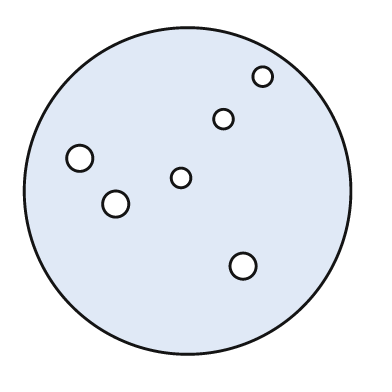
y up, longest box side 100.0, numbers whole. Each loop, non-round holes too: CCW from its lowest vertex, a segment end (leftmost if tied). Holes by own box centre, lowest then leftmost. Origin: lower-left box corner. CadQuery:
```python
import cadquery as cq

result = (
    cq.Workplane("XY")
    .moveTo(50.0, 50.0)
    .circle(50.0)
    .moveTo(67.0, 27.0)
    .circle(4.0)
    .moveTo(28.0, 46.0)
    .circle(4.0)
    .moveTo(48.0, 54.0)
    .circle(3.0)
    .moveTo(17.0, 60.0)
    .circle(4.0)
    .moveTo(61.0, 72.0)
    .circle(3.0)
    .moveTo(73.0, 85.0)
    .circle(3.0)
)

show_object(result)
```